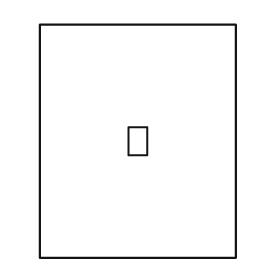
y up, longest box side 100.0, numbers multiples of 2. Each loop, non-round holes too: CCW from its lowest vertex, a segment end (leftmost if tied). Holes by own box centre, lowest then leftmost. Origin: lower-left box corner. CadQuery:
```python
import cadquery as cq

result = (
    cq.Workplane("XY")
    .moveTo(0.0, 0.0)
    .lineTo(84.0, 0.0)
    .lineTo(84.0, 100.0)
    .lineTo(0.0, 100.0)
    .close()
    .moveTo(38.0, 44.0)
    .lineTo(46.0, 44.0)
    .lineTo(46.0, 56.0)
    .lineTo(38.0, 56.0)
    .close()
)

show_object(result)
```